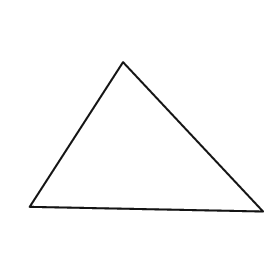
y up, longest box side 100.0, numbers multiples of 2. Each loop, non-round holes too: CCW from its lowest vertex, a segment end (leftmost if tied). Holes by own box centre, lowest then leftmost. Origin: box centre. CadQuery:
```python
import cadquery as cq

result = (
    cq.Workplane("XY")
    .moveTo(50.0, -32.0)
    .lineTo(-10.0, 32.0)
    .lineTo(-50.0, -30.0)
    .close()
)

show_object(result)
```